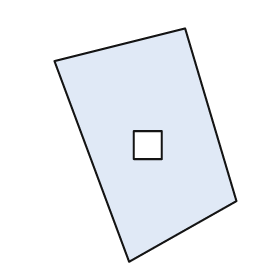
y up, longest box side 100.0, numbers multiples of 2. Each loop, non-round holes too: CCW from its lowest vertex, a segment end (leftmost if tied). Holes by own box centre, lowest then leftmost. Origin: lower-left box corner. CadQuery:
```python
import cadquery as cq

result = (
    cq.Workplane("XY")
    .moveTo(32.0, 0.0)
    .lineTo(78.0, 26.0)
    .lineTo(56.0, 100.0)
    .lineTo(0.0, 86.0)
    .close()
    .moveTo(34.0, 44.0)
    .lineTo(46.0, 44.0)
    .lineTo(46.0, 56.0)
    .lineTo(34.0, 56.0)
    .close()
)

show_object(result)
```